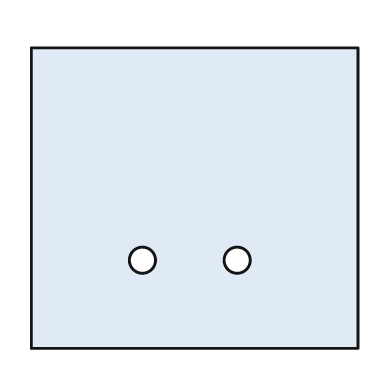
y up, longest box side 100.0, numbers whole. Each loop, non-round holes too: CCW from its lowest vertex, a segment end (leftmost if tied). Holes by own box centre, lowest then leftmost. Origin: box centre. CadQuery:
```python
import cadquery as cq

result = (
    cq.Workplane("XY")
    .moveTo(-50.0, -46.0)
    .lineTo(50.0, -46.0)
    .lineTo(50.0, 46.0)
    .lineTo(-50.0, 46.0)
    .close()
    .moveTo(-16.0, -19.0)
    .circle(4.0)
    .moveTo(13.0, -19.0)
    .circle(4.0)
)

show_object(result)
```